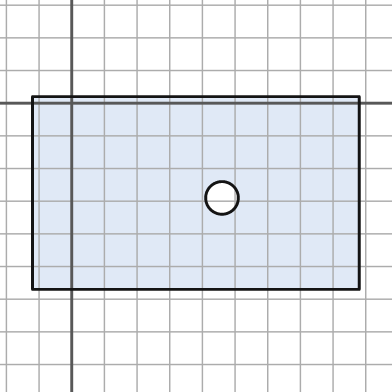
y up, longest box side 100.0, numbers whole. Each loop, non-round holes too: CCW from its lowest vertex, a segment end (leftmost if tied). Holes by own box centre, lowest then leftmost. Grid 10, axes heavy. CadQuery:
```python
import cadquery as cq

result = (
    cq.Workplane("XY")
    .moveTo(-12.0, -57.0)
    .lineTo(88.0, -57.0)
    .lineTo(88.0, 2.0)
    .lineTo(-12.0, 2.0)
    .close()
    .moveTo(46.0, -29.0)
    .circle(5.0)
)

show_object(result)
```